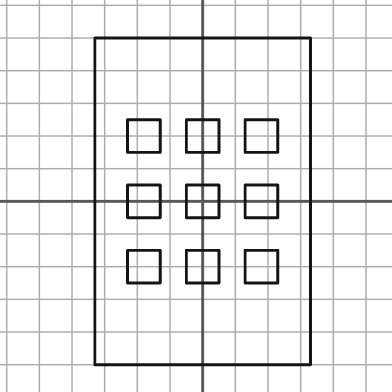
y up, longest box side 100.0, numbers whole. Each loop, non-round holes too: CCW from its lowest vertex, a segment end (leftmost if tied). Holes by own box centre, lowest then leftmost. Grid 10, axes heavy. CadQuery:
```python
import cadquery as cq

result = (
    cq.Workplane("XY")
    .moveTo(-33.0, -50.0)
    .lineTo(33.0, -50.0)
    .lineTo(33.0, 50.0)
    .lineTo(-33.0, 50.0)
    .close()
    .moveTo(-23.0, -25.0)
    .lineTo(-13.0, -25.0)
    .lineTo(-13.0, -15.0)
    .lineTo(-23.0, -15.0)
    .close()
    .moveTo(-5.0, -25.0)
    .lineTo(5.0, -25.0)
    .lineTo(5.0, -15.0)
    .lineTo(-5.0, -15.0)
    .close()
    .moveTo(13.0, -25.0)
    .lineTo(23.0, -25.0)
    .lineTo(23.0, -15.0)
    .lineTo(13.0, -15.0)
    .close()
    .moveTo(-23.0, -5.0)
    .lineTo(-13.0, -5.0)
    .lineTo(-13.0, 5.0)
    .lineTo(-23.0, 5.0)
    .close()
    .moveTo(-5.0, -5.0)
    .lineTo(5.0, -5.0)
    .lineTo(5.0, 5.0)
    .lineTo(-5.0, 5.0)
    .close()
    .moveTo(13.0, -5.0)
    .lineTo(23.0, -5.0)
    .lineTo(23.0, 5.0)
    .lineTo(13.0, 5.0)
    .close()
    .moveTo(-23.0, 15.0)
    .lineTo(-13.0, 15.0)
    .lineTo(-13.0, 25.0)
    .lineTo(-23.0, 25.0)
    .close()
    .moveTo(-5.0, 15.0)
    .lineTo(5.0, 15.0)
    .lineTo(5.0, 25.0)
    .lineTo(-5.0, 25.0)
    .close()
    .moveTo(13.0, 15.0)
    .lineTo(23.0, 15.0)
    .lineTo(23.0, 25.0)
    .lineTo(13.0, 25.0)
    .close()
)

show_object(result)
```